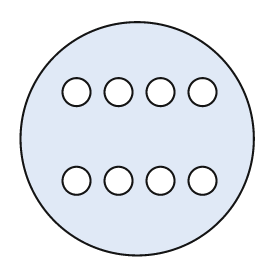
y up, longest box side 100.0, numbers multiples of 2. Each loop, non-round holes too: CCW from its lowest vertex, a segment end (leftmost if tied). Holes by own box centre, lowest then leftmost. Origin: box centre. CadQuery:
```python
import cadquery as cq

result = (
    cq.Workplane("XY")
    .moveTo(0.0, 0.0)
    .circle(50.0)
    .moveTo(-26.0, -18.0)
    .circle(6.0)
    .moveTo(-8.0, -18.0)
    .circle(6.0)
    .moveTo(10.0, -18.0)
    .circle(6.0)
    .moveTo(28.0, -18.0)
    .circle(6.0)
    .moveTo(-26.0, 20.0)
    .circle(6.0)
    .moveTo(-8.0, 20.0)
    .circle(6.0)
    .moveTo(10.0, 20.0)
    .circle(6.0)
    .moveTo(28.0, 20.0)
    .circle(6.0)
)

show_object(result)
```